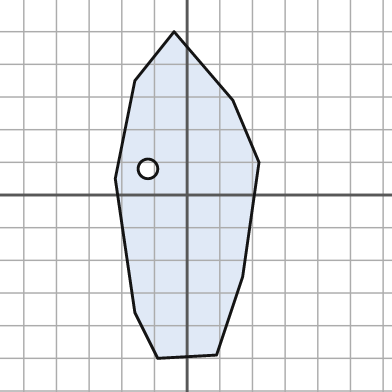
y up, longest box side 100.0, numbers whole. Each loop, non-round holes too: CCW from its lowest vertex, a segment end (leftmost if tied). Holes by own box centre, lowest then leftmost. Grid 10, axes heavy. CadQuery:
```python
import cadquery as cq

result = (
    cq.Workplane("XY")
    .moveTo(-9.0, -50.0)
    .lineTo(9.0, -49.0)
    .lineTo(17.0, -25.0)
    .lineTo(22.0, 10.0)
    .lineTo(14.0, 29.0)
    .lineTo(-4.0, 50.0)
    .lineTo(-16.0, 35.0)
    .lineTo(-22.0, 5.0)
    .lineTo(-16.0, -36.0)
    .close()
    .moveTo(-12.0, 8.0)
    .circle(3.0)
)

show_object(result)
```